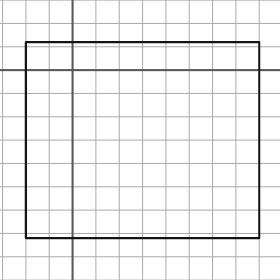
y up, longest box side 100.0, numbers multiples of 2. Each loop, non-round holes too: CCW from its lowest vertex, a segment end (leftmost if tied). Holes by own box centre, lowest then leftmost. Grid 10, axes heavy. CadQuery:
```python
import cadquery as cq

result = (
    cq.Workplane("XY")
    .moveTo(-20.0, -72.0)
    .lineTo(80.0, -72.0)
    .lineTo(80.0, 12.0)
    .lineTo(-20.0, 12.0)
    .close()
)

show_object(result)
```